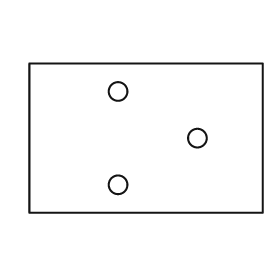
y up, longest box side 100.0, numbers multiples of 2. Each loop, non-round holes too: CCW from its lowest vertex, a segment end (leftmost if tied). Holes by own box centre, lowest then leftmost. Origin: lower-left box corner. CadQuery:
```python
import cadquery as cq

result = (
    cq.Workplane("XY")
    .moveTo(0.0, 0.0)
    .lineTo(100.0, 0.0)
    .lineTo(100.0, 64.0)
    .lineTo(0.0, 64.0)
    .close()
    .moveTo(38.0, 12.0)
    .circle(4.0)
    .moveTo(72.0, 32.0)
    .circle(4.0)
    .moveTo(38.0, 52.0)
    .circle(4.0)
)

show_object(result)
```